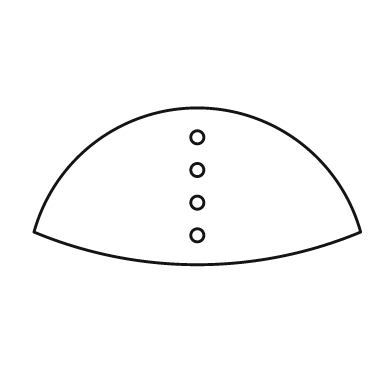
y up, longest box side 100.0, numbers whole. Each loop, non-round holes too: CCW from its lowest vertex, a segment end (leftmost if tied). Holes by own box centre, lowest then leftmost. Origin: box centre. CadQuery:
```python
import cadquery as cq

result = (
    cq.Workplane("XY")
    .moveTo(-50.0, -14.0)
    .threePointArc((0.0, -24.0), (50.0, -14.0))
    .threePointArc((0.0, 24.0), (-50.0, -14.0))
    .close()
    .moveTo(0.0, -15.0)
    .circle(2.0)
    .moveTo(0.0, -5.0)
    .circle(2.0)
    .moveTo(0.0, 5.0)
    .circle(2.0)
    .moveTo(0.0, 15.0)
    .circle(2.0)
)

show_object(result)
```